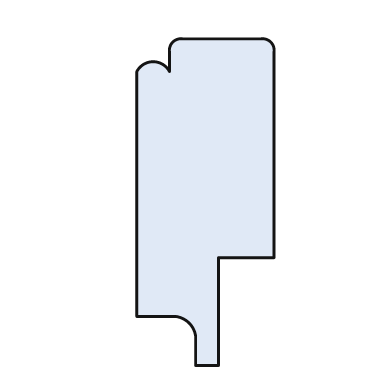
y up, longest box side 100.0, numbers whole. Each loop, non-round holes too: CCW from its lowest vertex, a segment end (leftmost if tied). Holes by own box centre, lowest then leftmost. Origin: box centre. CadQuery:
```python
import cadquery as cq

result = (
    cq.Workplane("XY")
    .moveTo(-3.0, -50.0)
    .lineTo(4.0, -50.0)
    .lineTo(4.0, -17.0)
    .lineTo(21.0, -17.0)
    .lineTo(21.0, 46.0)
    .threePointArc((20.0, 49.0), (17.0, 50.0))
    .lineTo(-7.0, 50.0)
    .threePointArc((-10.0, 49.0), (-11.0, 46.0))
    .lineTo(-11.0, 40.0)
    .threePointArc((-16.0, 43.0), (-21.0, 40.0))
    .lineTo(-21.0, -35.0)
    .lineTo(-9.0, -35.0)
    .threePointArc((-5.0, -37.0), (-3.0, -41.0))
    .close()
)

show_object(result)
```